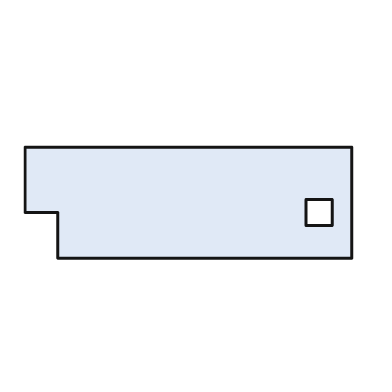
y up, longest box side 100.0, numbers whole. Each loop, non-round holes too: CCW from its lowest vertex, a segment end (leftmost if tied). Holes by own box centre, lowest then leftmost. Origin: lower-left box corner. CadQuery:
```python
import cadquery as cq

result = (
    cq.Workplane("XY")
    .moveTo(10.0, 0.0)
    .lineTo(100.0, 0.0)
    .lineTo(100.0, 34.0)
    .lineTo(0.0, 34.0)
    .lineTo(0.0, 14.0)
    .lineTo(10.0, 14.0)
    .close()
    .moveTo(86.0, 10.0)
    .lineTo(94.0, 10.0)
    .lineTo(94.0, 18.0)
    .lineTo(86.0, 18.0)
    .close()
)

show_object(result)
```